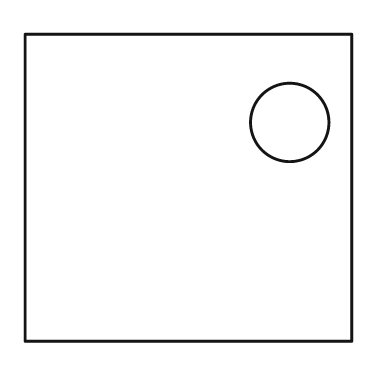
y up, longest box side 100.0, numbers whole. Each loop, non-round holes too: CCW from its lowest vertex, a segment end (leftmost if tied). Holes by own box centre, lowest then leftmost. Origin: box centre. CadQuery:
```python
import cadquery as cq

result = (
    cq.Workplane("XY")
    .moveTo(-50.0, -47.0)
    .lineTo(50.0, -47.0)
    .lineTo(50.0, 47.0)
    .lineTo(-50.0, 47.0)
    .close()
    .moveTo(31.0, 20.0)
    .circle(12.0)
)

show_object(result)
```